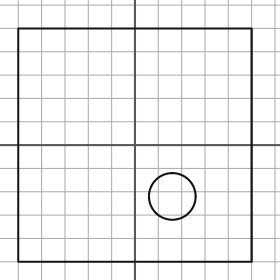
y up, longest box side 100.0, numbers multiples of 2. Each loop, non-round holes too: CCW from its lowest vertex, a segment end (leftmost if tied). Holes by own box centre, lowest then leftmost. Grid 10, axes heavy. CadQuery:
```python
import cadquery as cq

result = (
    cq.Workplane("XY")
    .moveTo(-50.0, -50.0)
    .lineTo(50.0, -50.0)
    .lineTo(50.0, 50.0)
    .lineTo(-50.0, 50.0)
    .close()
    .moveTo(16.0, -22.0)
    .circle(10.0)
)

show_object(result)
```